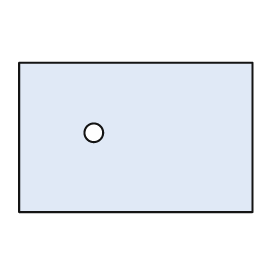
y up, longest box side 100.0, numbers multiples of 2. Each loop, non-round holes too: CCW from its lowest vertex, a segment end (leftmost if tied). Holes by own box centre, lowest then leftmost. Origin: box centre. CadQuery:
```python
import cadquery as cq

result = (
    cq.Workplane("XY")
    .moveTo(-50.0, -32.0)
    .lineTo(50.0, -32.0)
    .lineTo(50.0, 32.0)
    .lineTo(-50.0, 32.0)
    .close()
    .moveTo(-18.0, 2.0)
    .circle(4.0)
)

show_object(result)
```